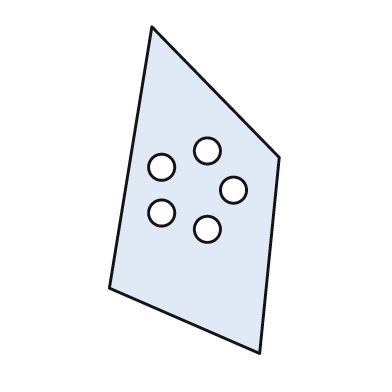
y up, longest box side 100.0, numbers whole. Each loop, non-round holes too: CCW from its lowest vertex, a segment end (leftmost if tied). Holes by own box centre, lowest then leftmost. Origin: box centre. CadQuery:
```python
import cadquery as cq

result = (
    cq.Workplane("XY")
    .moveTo(20.0, -50.0)
    .lineTo(26.0, 10.0)
    .lineTo(-13.0, 50.0)
    .lineTo(-26.0, -30.0)
    .close()
    .moveTo(4.0, -12.0)
    .circle(4.0)
    .moveTo(-10.0, -7.0)
    .circle(4.0)
    .moveTo(12.0, 0.0)
    .circle(4.0)
    .moveTo(-10.0, 7.0)
    .circle(4.0)
    .moveTo(4.0, 12.0)
    .circle(4.0)
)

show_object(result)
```